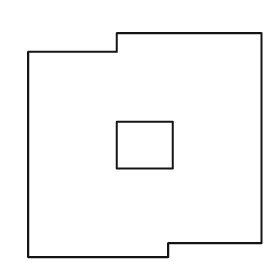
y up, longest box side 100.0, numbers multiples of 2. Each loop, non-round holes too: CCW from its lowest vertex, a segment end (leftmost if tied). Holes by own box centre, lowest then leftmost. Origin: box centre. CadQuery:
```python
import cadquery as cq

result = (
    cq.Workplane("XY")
    .moveTo(-50.0, -48.0)
    .lineTo(10.0, -48.0)
    .lineTo(10.0, -42.0)
    .lineTo(50.0, -42.0)
    .lineTo(50.0, 48.0)
    .lineTo(-12.0, 48.0)
    .lineTo(-12.0, 40.0)
    .lineTo(-50.0, 40.0)
    .close()
    .moveTo(-12.0, -10.0)
    .lineTo(12.0, -10.0)
    .lineTo(12.0, 10.0)
    .lineTo(-12.0, 10.0)
    .close()
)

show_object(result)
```